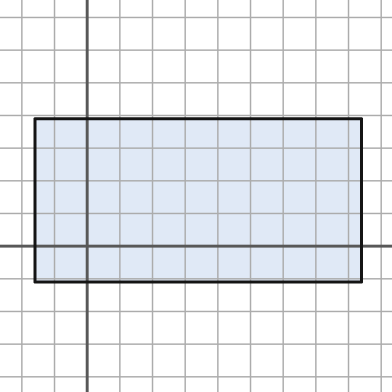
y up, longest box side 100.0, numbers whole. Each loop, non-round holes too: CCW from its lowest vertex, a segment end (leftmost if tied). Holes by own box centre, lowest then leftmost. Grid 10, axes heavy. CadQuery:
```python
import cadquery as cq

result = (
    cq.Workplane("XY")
    .moveTo(-16.0, -11.0)
    .lineTo(84.0, -11.0)
    .lineTo(84.0, 39.0)
    .lineTo(-16.0, 39.0)
    .close()
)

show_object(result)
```